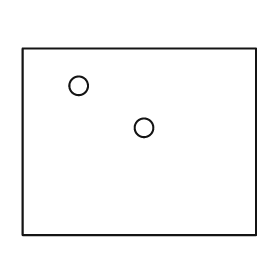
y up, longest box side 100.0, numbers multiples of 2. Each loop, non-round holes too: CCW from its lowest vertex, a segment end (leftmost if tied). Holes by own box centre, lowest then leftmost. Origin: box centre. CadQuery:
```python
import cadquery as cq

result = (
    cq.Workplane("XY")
    .moveTo(-50.0, -40.0)
    .lineTo(50.0, -40.0)
    .lineTo(50.0, 40.0)
    .lineTo(-50.0, 40.0)
    .close()
    .moveTo(2.0, 6.0)
    .circle(4.0)
    .moveTo(-26.0, 24.0)
    .circle(4.0)
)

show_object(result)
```